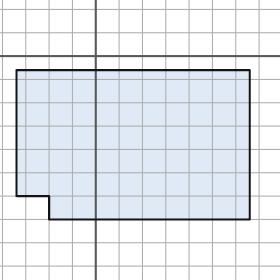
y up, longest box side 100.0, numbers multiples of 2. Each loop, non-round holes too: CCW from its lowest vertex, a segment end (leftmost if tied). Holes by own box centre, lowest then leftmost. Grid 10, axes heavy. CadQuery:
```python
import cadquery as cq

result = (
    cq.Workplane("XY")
    .moveTo(-20.0, -70.0)
    .lineTo(66.0, -70.0)
    .lineTo(66.0, -6.0)
    .lineTo(-34.0, -6.0)
    .lineTo(-34.0, -60.0)
    .lineTo(-20.0, -60.0)
    .close()
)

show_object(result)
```